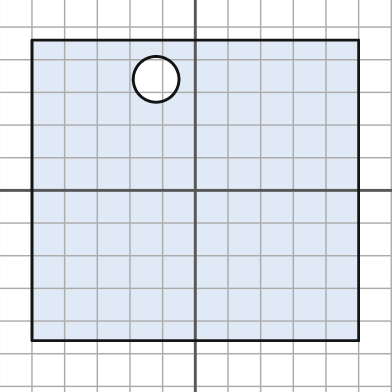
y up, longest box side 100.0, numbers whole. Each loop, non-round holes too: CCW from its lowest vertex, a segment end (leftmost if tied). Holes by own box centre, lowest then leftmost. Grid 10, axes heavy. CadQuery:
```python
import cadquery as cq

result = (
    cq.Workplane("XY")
    .moveTo(-50.0, -46.0)
    .lineTo(50.0, -46.0)
    .lineTo(50.0, 46.0)
    .lineTo(-50.0, 46.0)
    .close()
    .moveTo(-12.0, 34.0)
    .circle(7.0)
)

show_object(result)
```